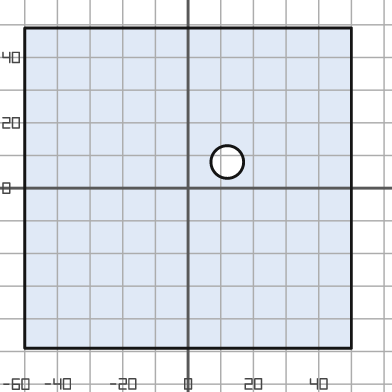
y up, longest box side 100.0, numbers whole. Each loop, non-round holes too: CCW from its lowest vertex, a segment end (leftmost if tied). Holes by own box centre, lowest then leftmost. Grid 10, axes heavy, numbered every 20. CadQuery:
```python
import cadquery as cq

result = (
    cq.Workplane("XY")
    .moveTo(-50.0, -49.0)
    .lineTo(50.0, -49.0)
    .lineTo(50.0, 49.0)
    .lineTo(-50.0, 49.0)
    .close()
    .moveTo(12.0, 8.0)
    .circle(5.0)
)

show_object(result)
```